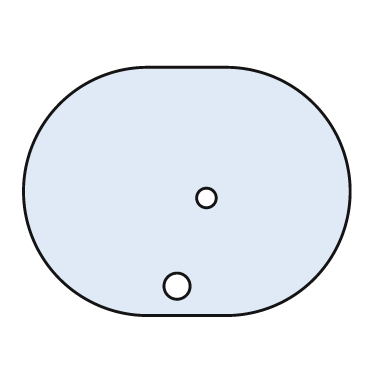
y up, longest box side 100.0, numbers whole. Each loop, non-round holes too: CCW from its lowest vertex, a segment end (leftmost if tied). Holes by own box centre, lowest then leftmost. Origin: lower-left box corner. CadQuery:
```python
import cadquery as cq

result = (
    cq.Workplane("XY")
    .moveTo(38.0, 0.0)
    .lineTo(62.0, 0.0)
    .threePointArc((100.0, 38.0), (62.0, 76.0))
    .lineTo(38.0, 76.0)
    .threePointArc((0.0, 38.0), (38.0, 0.0))
    .close()
    .moveTo(47.0, 9.0)
    .circle(4.0)
    .moveTo(56.0, 36.0)
    .circle(3.0)
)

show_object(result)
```